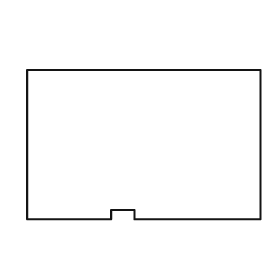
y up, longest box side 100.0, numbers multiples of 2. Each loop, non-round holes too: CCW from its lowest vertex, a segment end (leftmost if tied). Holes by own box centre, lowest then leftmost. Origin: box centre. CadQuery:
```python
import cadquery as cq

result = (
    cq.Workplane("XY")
    .moveTo(-50.0, -32.0)
    .lineTo(-14.0, -32.0)
    .lineTo(-14.0, -28.0)
    .lineTo(-4.0, -28.0)
    .lineTo(-4.0, -32.0)
    .lineTo(50.0, -32.0)
    .lineTo(50.0, 32.0)
    .lineTo(-50.0, 32.0)
    .close()
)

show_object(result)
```